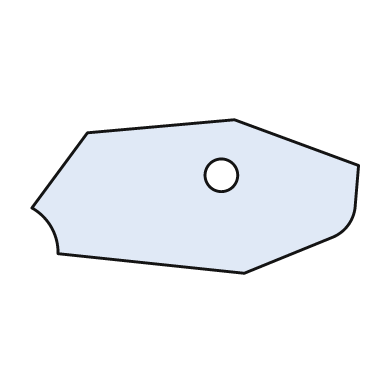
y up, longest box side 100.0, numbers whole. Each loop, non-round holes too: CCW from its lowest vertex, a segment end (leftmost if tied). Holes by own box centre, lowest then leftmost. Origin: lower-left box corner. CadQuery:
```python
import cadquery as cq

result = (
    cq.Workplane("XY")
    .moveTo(65.0, 0.0)
    .lineTo(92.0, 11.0)
    .threePointArc((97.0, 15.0), (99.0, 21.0))
    .lineTo(100.0, 33.0)
    .lineTo(62.0, 47.0)
    .lineTo(17.0, 43.0)
    .lineTo(0.0, 20.0)
    .threePointArc((6.0, 14.0), (8.0, 6.0))
    .close()
    .moveTo(58.0, 30.0)
    .circle(5.0)
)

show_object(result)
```